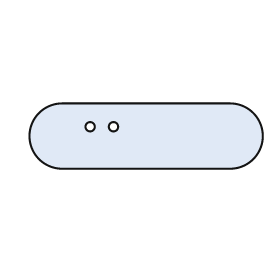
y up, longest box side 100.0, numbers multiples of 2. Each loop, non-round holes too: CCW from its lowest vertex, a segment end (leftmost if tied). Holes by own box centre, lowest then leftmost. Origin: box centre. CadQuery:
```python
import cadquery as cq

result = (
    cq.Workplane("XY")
    .moveTo(-36.0, -14.0)
    .lineTo(36.0, -14.0)
    .threePointArc((50.0, 0.0), (36.0, 14.0))
    .lineTo(-36.0, 14.0)
    .threePointArc((-50.0, 0.0), (-36.0, -14.0))
    .close()
    .moveTo(-24.0, 4.0)
    .circle(2.0)
    .moveTo(-14.0, 4.0)
    .circle(2.0)
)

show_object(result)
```